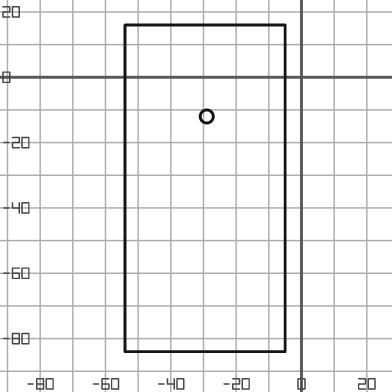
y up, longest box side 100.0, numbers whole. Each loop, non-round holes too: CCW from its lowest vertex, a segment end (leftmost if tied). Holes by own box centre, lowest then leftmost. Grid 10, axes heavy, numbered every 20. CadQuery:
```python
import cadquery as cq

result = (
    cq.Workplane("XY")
    .moveTo(-54.0, -84.0)
    .lineTo(-5.0, -84.0)
    .lineTo(-5.0, 16.0)
    .lineTo(-54.0, 16.0)
    .close()
    .moveTo(-29.0, -12.0)
    .circle(2.0)
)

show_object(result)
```